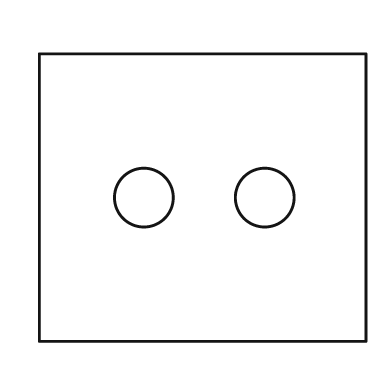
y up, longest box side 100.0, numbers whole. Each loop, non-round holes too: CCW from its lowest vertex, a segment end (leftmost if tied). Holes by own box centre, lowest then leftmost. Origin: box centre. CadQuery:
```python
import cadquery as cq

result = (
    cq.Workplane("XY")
    .moveTo(-50.0, -44.0)
    .lineTo(50.0, -44.0)
    .lineTo(50.0, 44.0)
    .lineTo(-50.0, 44.0)
    .close()
    .moveTo(-18.0, 0.0)
    .circle(9.0)
    .moveTo(19.0, 0.0)
    .circle(9.0)
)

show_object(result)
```